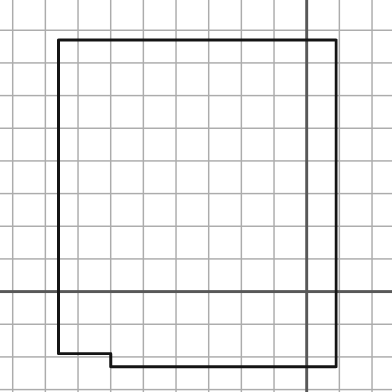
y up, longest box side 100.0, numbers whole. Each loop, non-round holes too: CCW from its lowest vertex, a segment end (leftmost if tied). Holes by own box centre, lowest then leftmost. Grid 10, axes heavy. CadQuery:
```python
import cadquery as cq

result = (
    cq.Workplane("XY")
    .moveTo(-60.0, -23.0)
    .lineTo(9.0, -23.0)
    .lineTo(9.0, 77.0)
    .lineTo(-76.0, 77.0)
    .lineTo(-76.0, -19.0)
    .lineTo(-60.0, -19.0)
    .close()
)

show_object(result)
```